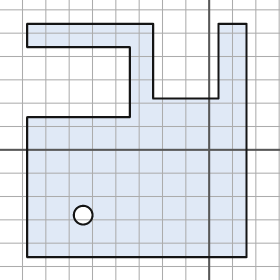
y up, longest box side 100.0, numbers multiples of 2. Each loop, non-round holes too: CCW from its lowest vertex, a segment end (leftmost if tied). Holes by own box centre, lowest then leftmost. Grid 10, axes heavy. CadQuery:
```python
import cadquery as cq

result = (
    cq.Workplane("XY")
    .moveTo(-78.0, -46.0)
    .lineTo(16.0, -46.0)
    .lineTo(16.0, 54.0)
    .lineTo(4.0, 54.0)
    .lineTo(4.0, 22.0)
    .lineTo(-24.0, 22.0)
    .lineTo(-24.0, 54.0)
    .lineTo(-78.0, 54.0)
    .lineTo(-78.0, 44.0)
    .lineTo(-34.0, 44.0)
    .lineTo(-34.0, 14.0)
    .lineTo(-78.0, 14.0)
    .close()
    .moveTo(-54.0, -28.0)
    .circle(4.0)
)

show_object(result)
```